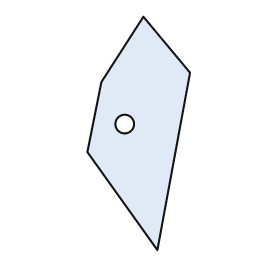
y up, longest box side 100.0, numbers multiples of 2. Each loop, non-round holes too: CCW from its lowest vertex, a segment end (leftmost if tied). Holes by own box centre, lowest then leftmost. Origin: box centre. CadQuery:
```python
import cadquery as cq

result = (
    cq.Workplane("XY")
    .moveTo(8.0, -50.0)
    .lineTo(22.0, 26.0)
    .lineTo(2.0, 50.0)
    .lineTo(-16.0, 22.0)
    .lineTo(-22.0, -8.0)
    .close()
    .moveTo(-6.0, 4.0)
    .circle(4.0)
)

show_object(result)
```